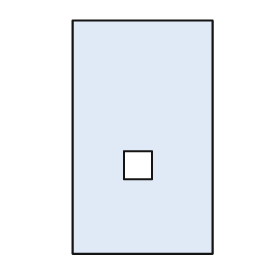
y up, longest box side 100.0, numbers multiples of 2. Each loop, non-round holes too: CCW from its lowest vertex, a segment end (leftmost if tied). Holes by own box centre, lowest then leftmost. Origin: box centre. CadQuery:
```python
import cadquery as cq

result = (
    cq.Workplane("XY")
    .moveTo(-30.0, -50.0)
    .lineTo(30.0, -50.0)
    .lineTo(30.0, 50.0)
    .lineTo(-30.0, 50.0)
    .close()
    .moveTo(-8.0, -18.0)
    .lineTo(4.0, -18.0)
    .lineTo(4.0, -6.0)
    .lineTo(-8.0, -6.0)
    .close()
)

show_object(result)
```